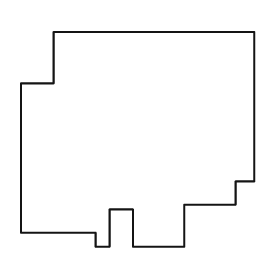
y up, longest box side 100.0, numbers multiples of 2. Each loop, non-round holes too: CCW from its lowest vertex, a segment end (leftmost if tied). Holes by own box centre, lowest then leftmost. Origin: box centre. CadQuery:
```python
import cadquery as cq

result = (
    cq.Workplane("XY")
    .moveTo(-18.0, -46.0)
    .lineTo(-12.0, -46.0)
    .lineTo(-12.0, -30.0)
    .lineTo(-2.0, -30.0)
    .lineTo(-2.0, -46.0)
    .lineTo(20.0, -46.0)
    .lineTo(20.0, -28.0)
    .lineTo(42.0, -28.0)
    .lineTo(42.0, -18.0)
    .lineTo(50.0, -18.0)
    .lineTo(50.0, 46.0)
    .lineTo(-36.0, 46.0)
    .lineTo(-36.0, 24.0)
    .lineTo(-50.0, 24.0)
    .lineTo(-50.0, -40.0)
    .lineTo(-18.0, -40.0)
    .close()
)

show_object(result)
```